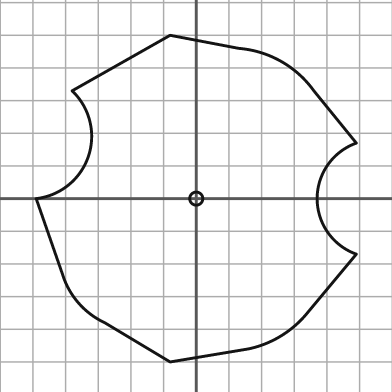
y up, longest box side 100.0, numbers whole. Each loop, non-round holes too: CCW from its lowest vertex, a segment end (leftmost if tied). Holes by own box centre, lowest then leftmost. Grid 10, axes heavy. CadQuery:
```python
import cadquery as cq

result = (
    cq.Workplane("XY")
    .moveTo(-8.0, -50.0)
    .lineTo(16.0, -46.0)
    .threePointArc((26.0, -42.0), (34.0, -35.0))
    .lineTo(49.0, -17.0)
    .threePointArc((37.0, 0.0), (49.0, 17.0))
    .lineTo(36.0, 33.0)
    .threePointArc((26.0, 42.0), (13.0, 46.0))
    .lineTo(-8.0, 50.0)
    .lineTo(-38.0, 33.0)
    .threePointArc((-33.0, 13.0), (-49.0, 0.0))
    .lineTo(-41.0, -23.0)
    .threePointArc((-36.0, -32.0), (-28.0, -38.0))
    .close()
    .moveTo(0.0, 0.0)
    .circle(2.0)
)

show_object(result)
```